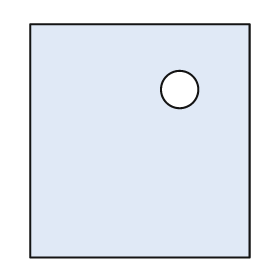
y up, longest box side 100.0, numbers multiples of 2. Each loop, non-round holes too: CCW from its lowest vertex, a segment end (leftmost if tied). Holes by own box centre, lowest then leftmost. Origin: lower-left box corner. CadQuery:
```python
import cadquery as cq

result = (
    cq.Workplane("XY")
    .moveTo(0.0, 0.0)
    .lineTo(94.0, 0.0)
    .lineTo(94.0, 100.0)
    .lineTo(0.0, 100.0)
    .close()
    .moveTo(64.0, 72.0)
    .circle(8.0)
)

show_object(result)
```